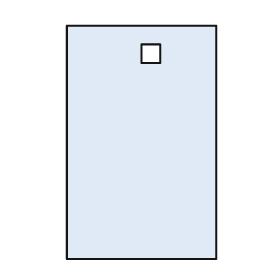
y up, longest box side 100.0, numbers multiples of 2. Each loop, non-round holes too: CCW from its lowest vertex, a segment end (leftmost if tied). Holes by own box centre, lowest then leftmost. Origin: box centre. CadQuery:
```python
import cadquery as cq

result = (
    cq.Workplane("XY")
    .moveTo(-32.0, -50.0)
    .lineTo(32.0, -50.0)
    .lineTo(32.0, 50.0)
    .lineTo(-32.0, 50.0)
    .close()
    .moveTo(0.0, 34.0)
    .lineTo(8.0, 34.0)
    .lineTo(8.0, 42.0)
    .lineTo(0.0, 42.0)
    .close()
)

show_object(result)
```